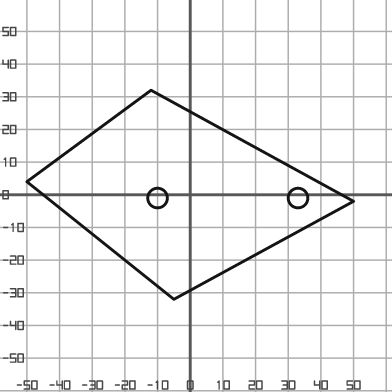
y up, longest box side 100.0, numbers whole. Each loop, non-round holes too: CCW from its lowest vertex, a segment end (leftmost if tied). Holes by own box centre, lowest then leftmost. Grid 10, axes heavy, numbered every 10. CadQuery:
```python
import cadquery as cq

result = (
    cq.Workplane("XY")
    .moveTo(-5.0, -32.0)
    .lineTo(50.0, -2.0)
    .lineTo(-12.0, 32.0)
    .lineTo(-50.0, 4.0)
    .close()
    .moveTo(-10.0, -1.0)
    .circle(3.0)
    .moveTo(33.0, -1.0)
    .circle(3.0)
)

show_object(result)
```